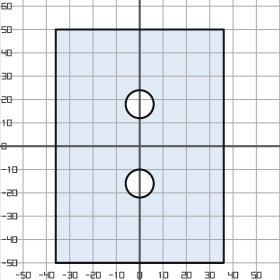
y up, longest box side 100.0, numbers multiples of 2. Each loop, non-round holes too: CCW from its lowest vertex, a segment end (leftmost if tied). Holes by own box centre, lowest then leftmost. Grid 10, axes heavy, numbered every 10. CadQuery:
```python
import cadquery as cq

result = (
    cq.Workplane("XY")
    .moveTo(-36.0, -50.0)
    .lineTo(36.0, -50.0)
    .lineTo(36.0, 50.0)
    .lineTo(-36.0, 50.0)
    .close()
    .moveTo(0.0, -16.0)
    .circle(6.0)
    .moveTo(0.0, 18.0)
    .circle(6.0)
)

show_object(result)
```